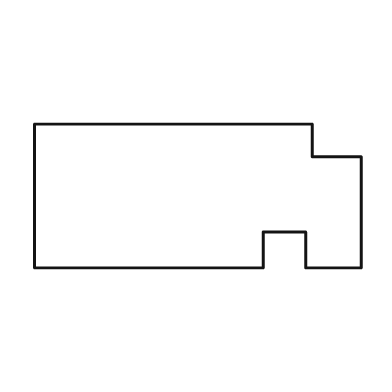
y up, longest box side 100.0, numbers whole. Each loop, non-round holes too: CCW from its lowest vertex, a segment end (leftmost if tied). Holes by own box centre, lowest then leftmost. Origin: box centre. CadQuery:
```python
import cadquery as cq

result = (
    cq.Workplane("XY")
    .moveTo(-50.0, -22.0)
    .lineTo(20.0, -22.0)
    .lineTo(20.0, -11.0)
    .lineTo(33.0, -11.0)
    .lineTo(33.0, -22.0)
    .lineTo(50.0, -22.0)
    .lineTo(50.0, 12.0)
    .lineTo(35.0, 12.0)
    .lineTo(35.0, 22.0)
    .lineTo(-50.0, 22.0)
    .close()
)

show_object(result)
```